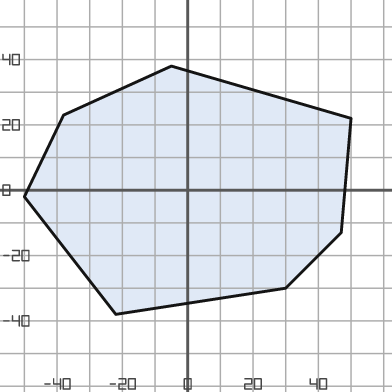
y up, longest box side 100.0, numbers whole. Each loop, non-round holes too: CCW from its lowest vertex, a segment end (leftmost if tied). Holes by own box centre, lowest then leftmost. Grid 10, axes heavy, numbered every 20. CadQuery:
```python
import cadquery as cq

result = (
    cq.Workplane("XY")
    .moveTo(-22.0, -38.0)
    .lineTo(30.0, -30.0)
    .lineTo(47.0, -13.0)
    .lineTo(50.0, 22.0)
    .lineTo(-5.0, 38.0)
    .lineTo(-38.0, 23.0)
    .lineTo(-50.0, -2.0)
    .close()
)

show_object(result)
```